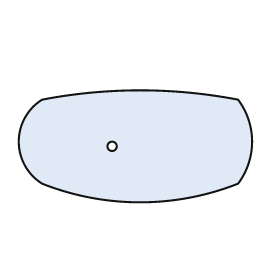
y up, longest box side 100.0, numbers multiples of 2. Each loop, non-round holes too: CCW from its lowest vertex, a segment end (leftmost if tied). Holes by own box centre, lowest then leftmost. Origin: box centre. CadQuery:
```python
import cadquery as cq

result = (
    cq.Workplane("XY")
    .moveTo(-40.0, -16.0)
    .threePointArc((2.0, -24.0), (44.0, -16.0))
    .threePointArc((50.0, 2.0), (44.0, 20.0))
    .threePointArc((2.0, 24.0), (-40.0, 20.0))
    .threePointArc((-50.0, 2.0), (-40.0, -16.0))
    .close()
    .moveTo(-10.0, 0.0)
    .circle(2.0)
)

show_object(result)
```